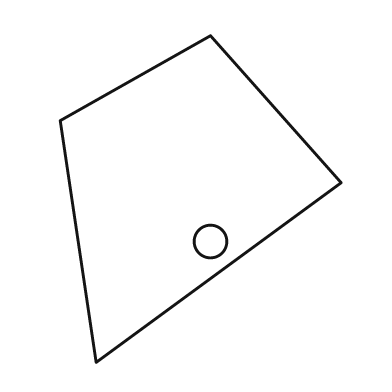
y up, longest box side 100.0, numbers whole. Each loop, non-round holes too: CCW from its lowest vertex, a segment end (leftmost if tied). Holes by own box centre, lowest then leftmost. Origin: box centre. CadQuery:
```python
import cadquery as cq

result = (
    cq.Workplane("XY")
    .moveTo(-32.0, -50.0)
    .lineTo(43.0, 5.0)
    .lineTo(3.0, 50.0)
    .lineTo(-43.0, 24.0)
    .close()
    .moveTo(3.0, -13.0)
    .circle(5.0)
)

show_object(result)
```